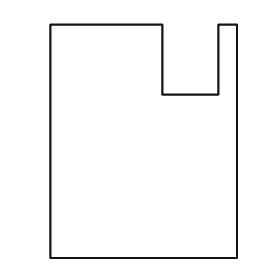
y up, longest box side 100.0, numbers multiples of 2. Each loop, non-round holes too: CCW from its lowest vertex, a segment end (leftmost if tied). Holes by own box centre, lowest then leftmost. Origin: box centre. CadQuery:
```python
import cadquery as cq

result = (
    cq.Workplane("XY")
    .moveTo(-40.0, -50.0)
    .lineTo(40.0, -50.0)
    .lineTo(40.0, 50.0)
    .lineTo(32.0, 50.0)
    .lineTo(32.0, 20.0)
    .lineTo(8.0, 20.0)
    .lineTo(8.0, 50.0)
    .lineTo(-40.0, 50.0)
    .close()
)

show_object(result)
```